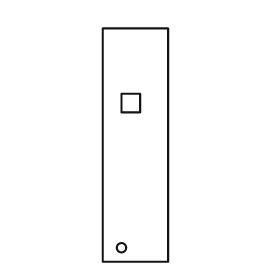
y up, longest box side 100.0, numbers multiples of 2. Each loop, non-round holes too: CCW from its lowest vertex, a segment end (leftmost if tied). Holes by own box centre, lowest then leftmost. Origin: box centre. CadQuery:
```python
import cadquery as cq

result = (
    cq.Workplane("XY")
    .moveTo(-14.0, -50.0)
    .lineTo(14.0, -50.0)
    .lineTo(14.0, 50.0)
    .lineTo(-14.0, 50.0)
    .close()
    .moveTo(-6.0, -44.0)
    .circle(2.0)
    .moveTo(-6.0, 14.0)
    .lineTo(2.0, 14.0)
    .lineTo(2.0, 22.0)
    .lineTo(-6.0, 22.0)
    .close()
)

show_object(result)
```